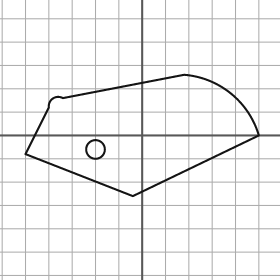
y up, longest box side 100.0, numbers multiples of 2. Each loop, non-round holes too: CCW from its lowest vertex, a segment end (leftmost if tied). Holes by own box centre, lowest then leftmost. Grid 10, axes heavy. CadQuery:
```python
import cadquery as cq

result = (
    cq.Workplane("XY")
    .moveTo(-4.0, -26.0)
    .lineTo(50.0, 0.0)
    .threePointArc((38.0, 18.0), (18.0, 26.0))
    .lineTo(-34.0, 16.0)
    .threePointArc((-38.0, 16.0), (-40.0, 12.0))
    .lineTo(-50.0, -8.0)
    .close()
    .moveTo(-20.0, -6.0)
    .circle(4.0)
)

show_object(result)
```